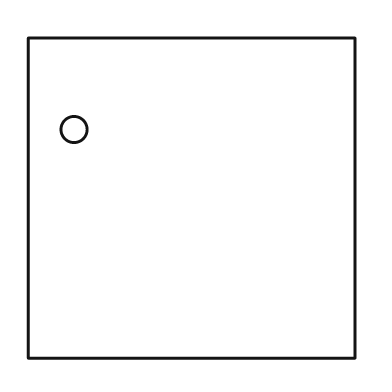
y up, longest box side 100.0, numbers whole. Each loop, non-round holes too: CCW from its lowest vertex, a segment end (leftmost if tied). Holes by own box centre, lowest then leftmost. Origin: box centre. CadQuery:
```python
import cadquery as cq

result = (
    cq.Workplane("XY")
    .moveTo(-50.0, -49.0)
    .lineTo(50.0, -49.0)
    .lineTo(50.0, 49.0)
    .lineTo(-50.0, 49.0)
    .close()
    .moveTo(-36.0, 21.0)
    .circle(4.0)
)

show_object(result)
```